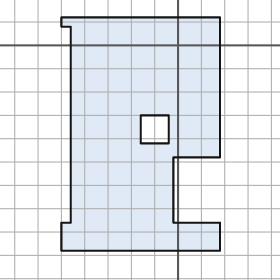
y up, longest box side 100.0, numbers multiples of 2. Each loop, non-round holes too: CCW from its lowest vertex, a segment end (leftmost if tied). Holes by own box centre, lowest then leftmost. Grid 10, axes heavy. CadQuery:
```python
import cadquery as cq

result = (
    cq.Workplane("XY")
    .moveTo(-50.0, -88.0)
    .lineTo(18.0, -88.0)
    .lineTo(18.0, -76.0)
    .lineTo(-2.0, -76.0)
    .lineTo(-2.0, -48.0)
    .lineTo(18.0, -48.0)
    .lineTo(18.0, 12.0)
    .lineTo(-50.0, 12.0)
    .lineTo(-50.0, 8.0)
    .lineTo(-46.0, 8.0)
    .lineTo(-46.0, -76.0)
    .lineTo(-50.0, -76.0)
    .close()
    .moveTo(-16.0, -42.0)
    .lineTo(-4.0, -42.0)
    .lineTo(-4.0, -30.0)
    .lineTo(-16.0, -30.0)
    .close()
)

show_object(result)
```